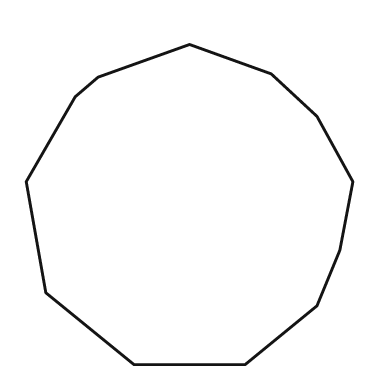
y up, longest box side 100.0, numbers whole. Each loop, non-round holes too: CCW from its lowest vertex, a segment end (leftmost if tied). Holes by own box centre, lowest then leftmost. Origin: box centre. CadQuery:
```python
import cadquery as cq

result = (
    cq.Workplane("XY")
    .moveTo(-17.0, -49.0)
    .lineTo(17.0, -49.0)
    .lineTo(39.0, -31.0)
    .lineTo(46.0, -14.0)
    .lineTo(50.0, 7.0)
    .lineTo(39.0, 27.0)
    .lineTo(25.0, 40.0)
    .lineTo(0.0, 49.0)
    .lineTo(-28.0, 39.0)
    .lineTo(-35.0, 33.0)
    .lineTo(-50.0, 7.0)
    .lineTo(-44.0, -27.0)
    .close()
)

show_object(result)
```